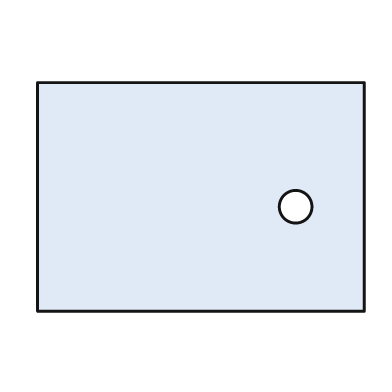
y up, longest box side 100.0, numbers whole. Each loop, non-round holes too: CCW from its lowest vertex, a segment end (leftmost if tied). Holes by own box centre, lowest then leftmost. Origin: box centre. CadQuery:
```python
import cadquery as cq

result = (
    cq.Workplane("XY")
    .moveTo(-50.0, -35.0)
    .lineTo(50.0, -35.0)
    .lineTo(50.0, 35.0)
    .lineTo(-50.0, 35.0)
    .close()
    .moveTo(29.0, -3.0)
    .circle(5.0)
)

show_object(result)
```